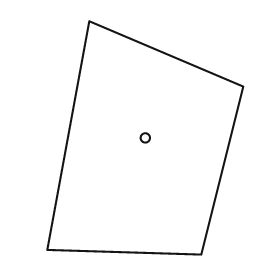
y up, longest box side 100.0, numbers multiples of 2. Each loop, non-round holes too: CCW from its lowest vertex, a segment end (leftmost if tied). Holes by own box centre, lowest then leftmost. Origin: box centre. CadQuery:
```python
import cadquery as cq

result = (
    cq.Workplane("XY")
    .moveTo(24.0, -50.0)
    .lineTo(42.0, 22.0)
    .lineTo(-24.0, 50.0)
    .lineTo(-42.0, -48.0)
    .close()
    .moveTo(0.0, 0.0)
    .circle(2.0)
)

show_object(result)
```